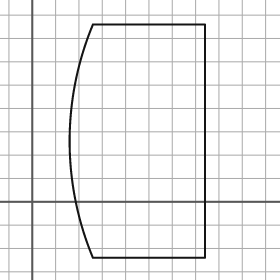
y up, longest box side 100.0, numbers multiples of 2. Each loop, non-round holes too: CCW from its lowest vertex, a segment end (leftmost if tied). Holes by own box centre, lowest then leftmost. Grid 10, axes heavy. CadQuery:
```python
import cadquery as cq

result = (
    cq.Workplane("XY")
    .moveTo(26.0, -24.0)
    .lineTo(74.0, -24.0)
    .lineTo(74.0, 76.0)
    .lineTo(26.0, 76.0)
    .threePointArc((16.0, 26.0), (26.0, -24.0))
    .close()
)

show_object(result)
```